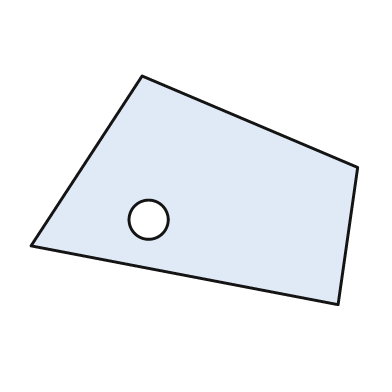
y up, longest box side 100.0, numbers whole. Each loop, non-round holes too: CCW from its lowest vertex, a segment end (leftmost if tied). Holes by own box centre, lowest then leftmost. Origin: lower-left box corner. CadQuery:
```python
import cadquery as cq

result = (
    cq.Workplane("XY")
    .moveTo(94.0, 0.0)
    .lineTo(100.0, 42.0)
    .lineTo(34.0, 70.0)
    .lineTo(0.0, 18.0)
    .close()
    .moveTo(36.0, 26.0)
    .circle(6.0)
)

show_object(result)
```